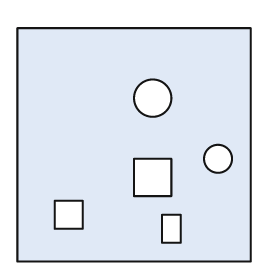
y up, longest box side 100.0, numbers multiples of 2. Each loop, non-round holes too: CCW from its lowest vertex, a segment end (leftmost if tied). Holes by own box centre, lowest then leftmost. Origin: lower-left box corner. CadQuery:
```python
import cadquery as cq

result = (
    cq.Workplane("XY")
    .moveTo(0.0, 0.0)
    .lineTo(100.0, 0.0)
    .lineTo(100.0, 100.0)
    .lineTo(0.0, 100.0)
    .close()
    .moveTo(62.0, 8.0)
    .lineTo(70.0, 8.0)
    .lineTo(70.0, 20.0)
    .lineTo(62.0, 20.0)
    .close()
    .moveTo(16.0, 14.0)
    .lineTo(28.0, 14.0)
    .lineTo(28.0, 26.0)
    .lineTo(16.0, 26.0)
    .close()
    .moveTo(50.0, 28.0)
    .lineTo(66.0, 28.0)
    .lineTo(66.0, 44.0)
    .lineTo(50.0, 44.0)
    .close()
    .moveTo(86.0, 44.0)
    .circle(6.0)
    .moveTo(58.0, 70.0)
    .circle(8.0)
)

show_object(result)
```